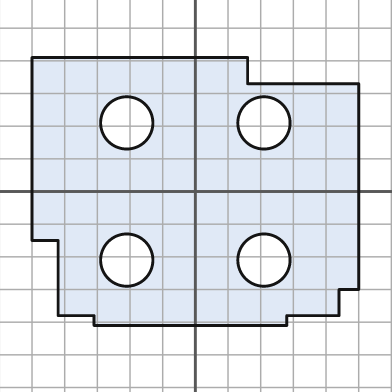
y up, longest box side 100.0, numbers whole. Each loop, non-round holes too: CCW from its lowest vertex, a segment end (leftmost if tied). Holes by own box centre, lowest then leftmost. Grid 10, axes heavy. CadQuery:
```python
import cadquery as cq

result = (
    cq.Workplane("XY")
    .moveTo(-31.0, -41.0)
    .lineTo(28.0, -41.0)
    .lineTo(28.0, -38.0)
    .lineTo(44.0, -38.0)
    .lineTo(44.0, -30.0)
    .lineTo(50.0, -30.0)
    .lineTo(50.0, 33.0)
    .lineTo(16.0, 33.0)
    .lineTo(16.0, 41.0)
    .lineTo(-50.0, 41.0)
    .lineTo(-50.0, -15.0)
    .lineTo(-42.0, -15.0)
    .lineTo(-42.0, -38.0)
    .lineTo(-31.0, -38.0)
    .close()
    .moveTo(-21.0, -21.0)
    .circle(8.0)
    .moveTo(21.0, -21.0)
    .circle(8.0)
    .moveTo(-21.0, 21.0)
    .circle(8.0)
    .moveTo(21.0, 21.0)
    .circle(8.0)
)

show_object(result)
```